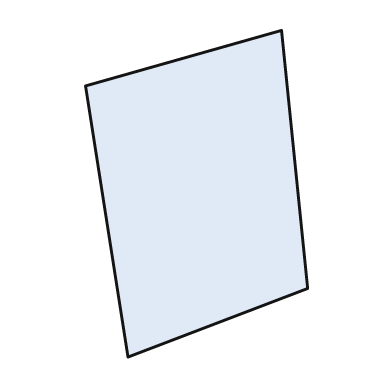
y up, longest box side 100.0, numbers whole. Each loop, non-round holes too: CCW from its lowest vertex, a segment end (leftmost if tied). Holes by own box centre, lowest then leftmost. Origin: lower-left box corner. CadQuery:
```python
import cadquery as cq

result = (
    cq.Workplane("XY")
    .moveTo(13.0, 0.0)
    .lineTo(68.0, 21.0)
    .lineTo(60.0, 100.0)
    .lineTo(0.0, 83.0)
    .close()
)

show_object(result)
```